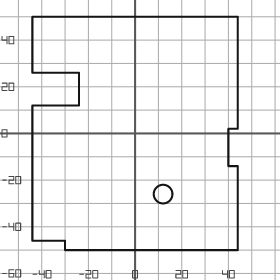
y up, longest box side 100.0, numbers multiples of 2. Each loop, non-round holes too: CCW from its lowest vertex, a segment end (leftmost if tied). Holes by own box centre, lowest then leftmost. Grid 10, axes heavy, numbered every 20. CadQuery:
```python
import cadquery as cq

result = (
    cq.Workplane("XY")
    .moveTo(-30.0, -50.0)
    .lineTo(44.0, -50.0)
    .lineTo(44.0, -14.0)
    .lineTo(40.0, -14.0)
    .lineTo(40.0, 2.0)
    .lineTo(44.0, 2.0)
    .lineTo(44.0, 50.0)
    .lineTo(-44.0, 50.0)
    .lineTo(-44.0, 26.0)
    .lineTo(-24.0, 26.0)
    .lineTo(-24.0, 12.0)
    .lineTo(-44.0, 12.0)
    .lineTo(-44.0, -46.0)
    .lineTo(-30.0, -46.0)
    .close()
    .moveTo(12.0, -26.0)
    .circle(4.0)
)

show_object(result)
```